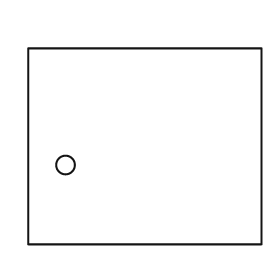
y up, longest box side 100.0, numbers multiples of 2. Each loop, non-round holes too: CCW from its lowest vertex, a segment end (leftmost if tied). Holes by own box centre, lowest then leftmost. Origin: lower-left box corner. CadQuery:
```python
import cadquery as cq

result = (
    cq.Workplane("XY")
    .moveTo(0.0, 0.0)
    .lineTo(100.0, 0.0)
    .lineTo(100.0, 84.0)
    .lineTo(0.0, 84.0)
    .close()
    .moveTo(16.0, 34.0)
    .circle(4.0)
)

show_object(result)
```